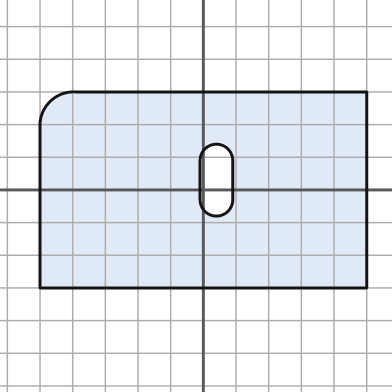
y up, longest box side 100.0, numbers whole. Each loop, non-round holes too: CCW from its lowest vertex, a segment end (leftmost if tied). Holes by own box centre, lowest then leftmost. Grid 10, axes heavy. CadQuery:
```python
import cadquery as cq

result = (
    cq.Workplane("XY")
    .moveTo(-50.0, -30.0)
    .lineTo(50.0, -30.0)
    .lineTo(50.0, 30.0)
    .lineTo(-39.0, 30.0)
    .threePointArc((-47.0, 27.0), (-50.0, 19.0))
    .close()
    .moveTo(-1.0, -3.0)
    .threePointArc((4.0, -8.0), (9.0, -3.0))
    .lineTo(9.0, 9.0)
    .threePointArc((4.0, 14.0), (-1.0, 9.0))
    .close()
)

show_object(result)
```